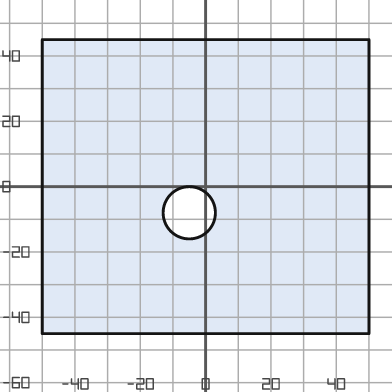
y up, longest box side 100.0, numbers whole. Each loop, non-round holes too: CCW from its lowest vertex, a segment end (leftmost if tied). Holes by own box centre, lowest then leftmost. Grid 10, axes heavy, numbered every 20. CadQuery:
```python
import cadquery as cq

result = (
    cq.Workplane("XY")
    .moveTo(-50.0, -45.0)
    .lineTo(50.0, -45.0)
    .lineTo(50.0, 45.0)
    .lineTo(-50.0, 45.0)
    .close()
    .moveTo(-5.0, -8.0)
    .circle(8.0)
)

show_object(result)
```